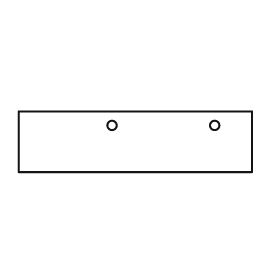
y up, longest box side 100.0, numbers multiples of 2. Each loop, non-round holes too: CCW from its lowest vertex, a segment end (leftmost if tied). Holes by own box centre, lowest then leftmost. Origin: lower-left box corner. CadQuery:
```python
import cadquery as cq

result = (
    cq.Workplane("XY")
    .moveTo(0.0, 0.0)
    .lineTo(100.0, 0.0)
    .lineTo(100.0, 26.0)
    .lineTo(0.0, 26.0)
    .close()
    .moveTo(40.0, 20.0)
    .circle(2.0)
    .moveTo(84.0, 20.0)
    .circle(2.0)
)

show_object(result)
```